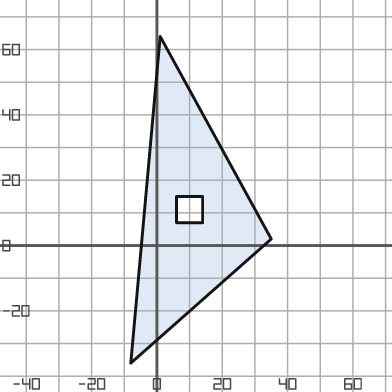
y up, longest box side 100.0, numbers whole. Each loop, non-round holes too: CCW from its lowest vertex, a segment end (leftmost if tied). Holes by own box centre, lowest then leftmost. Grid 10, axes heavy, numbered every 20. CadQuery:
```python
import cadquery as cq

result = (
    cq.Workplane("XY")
    .moveTo(-8.0, -36.0)
    .lineTo(35.0, 2.0)
    .lineTo(1.0, 64.0)
    .close()
    .moveTo(6.0, 7.0)
    .lineTo(14.0, 7.0)
    .lineTo(14.0, 15.0)
    .lineTo(6.0, 15.0)
    .close()
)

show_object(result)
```